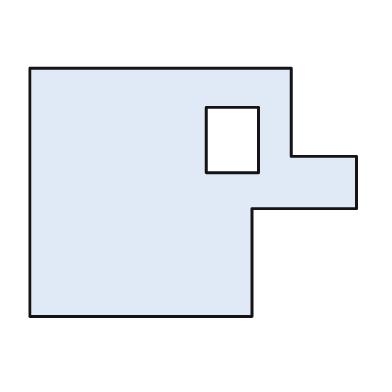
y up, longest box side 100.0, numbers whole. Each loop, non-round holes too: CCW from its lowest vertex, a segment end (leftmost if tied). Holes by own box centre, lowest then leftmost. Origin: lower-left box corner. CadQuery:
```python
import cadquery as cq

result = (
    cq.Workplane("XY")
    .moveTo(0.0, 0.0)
    .lineTo(68.0, 0.0)
    .lineTo(68.0, 33.0)
    .lineTo(100.0, 33.0)
    .lineTo(100.0, 49.0)
    .lineTo(80.0, 49.0)
    .lineTo(80.0, 76.0)
    .lineTo(0.0, 76.0)
    .close()
    .moveTo(54.0, 44.0)
    .lineTo(70.0, 44.0)
    .lineTo(70.0, 64.0)
    .lineTo(54.0, 64.0)
    .close()
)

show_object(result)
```